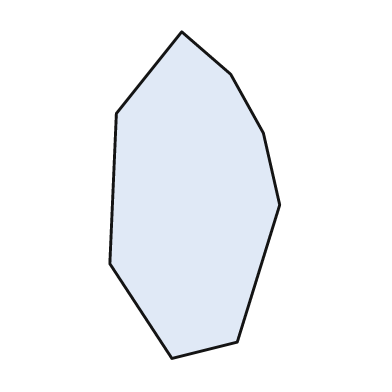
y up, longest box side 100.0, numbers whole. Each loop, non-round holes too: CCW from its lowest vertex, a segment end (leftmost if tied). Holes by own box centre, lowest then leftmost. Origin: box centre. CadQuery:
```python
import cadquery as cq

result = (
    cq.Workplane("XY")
    .moveTo(-7.0, -50.0)
    .lineTo(13.0, -45.0)
    .lineTo(26.0, -3.0)
    .lineTo(21.0, 19.0)
    .lineTo(11.0, 37.0)
    .lineTo(-4.0, 50.0)
    .lineTo(-24.0, 25.0)
    .lineTo(-26.0, -21.0)
    .close()
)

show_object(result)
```